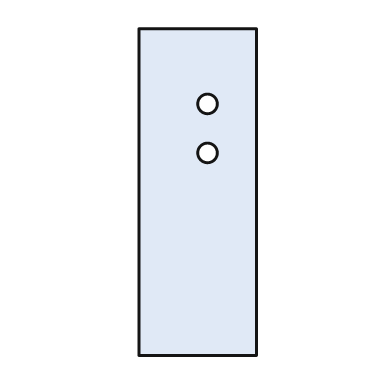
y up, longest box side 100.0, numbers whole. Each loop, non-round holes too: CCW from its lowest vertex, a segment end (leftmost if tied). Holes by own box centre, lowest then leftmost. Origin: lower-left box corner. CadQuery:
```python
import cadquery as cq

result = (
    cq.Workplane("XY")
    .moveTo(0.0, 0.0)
    .lineTo(36.0, 0.0)
    .lineTo(36.0, 100.0)
    .lineTo(0.0, 100.0)
    .close()
    .moveTo(21.0, 62.0)
    .circle(3.0)
    .moveTo(21.0, 77.0)
    .circle(3.0)
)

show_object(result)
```